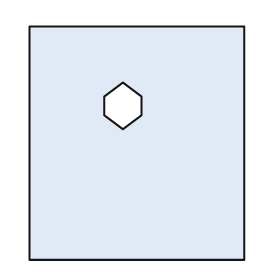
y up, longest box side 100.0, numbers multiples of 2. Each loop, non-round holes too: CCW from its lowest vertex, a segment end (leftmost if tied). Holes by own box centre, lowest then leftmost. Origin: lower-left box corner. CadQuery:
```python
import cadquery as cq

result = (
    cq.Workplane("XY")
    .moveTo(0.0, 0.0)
    .lineTo(92.0, 0.0)
    .lineTo(92.0, 100.0)
    .lineTo(0.0, 100.0)
    .close()
    .moveTo(40.0, 56.0)
    .lineTo(48.0, 62.0)
    .lineTo(48.0, 70.0)
    .lineTo(40.0, 76.0)
    .lineTo(32.0, 70.0)
    .lineTo(32.0, 62.0)
    .close()
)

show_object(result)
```